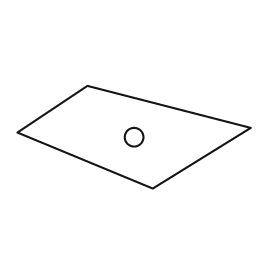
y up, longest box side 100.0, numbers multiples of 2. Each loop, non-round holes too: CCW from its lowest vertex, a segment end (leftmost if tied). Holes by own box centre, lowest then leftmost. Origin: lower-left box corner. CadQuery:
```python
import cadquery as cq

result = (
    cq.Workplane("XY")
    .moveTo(58.0, 0.0)
    .lineTo(100.0, 26.0)
    .lineTo(30.0, 44.0)
    .lineTo(0.0, 24.0)
    .close()
    .moveTo(50.0, 22.0)
    .circle(4.0)
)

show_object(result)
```